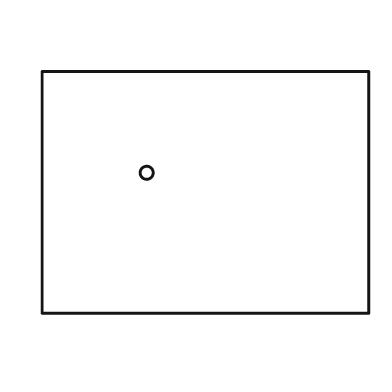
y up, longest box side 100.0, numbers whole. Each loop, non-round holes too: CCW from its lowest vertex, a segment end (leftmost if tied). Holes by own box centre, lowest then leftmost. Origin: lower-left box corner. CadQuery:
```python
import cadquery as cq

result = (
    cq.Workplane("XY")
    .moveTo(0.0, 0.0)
    .lineTo(100.0, 0.0)
    .lineTo(100.0, 74.0)
    .lineTo(0.0, 74.0)
    .close()
    .moveTo(32.0, 43.0)
    .circle(2.0)
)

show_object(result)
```